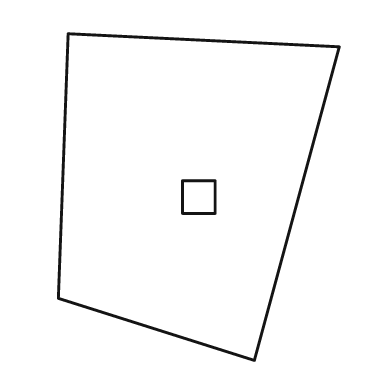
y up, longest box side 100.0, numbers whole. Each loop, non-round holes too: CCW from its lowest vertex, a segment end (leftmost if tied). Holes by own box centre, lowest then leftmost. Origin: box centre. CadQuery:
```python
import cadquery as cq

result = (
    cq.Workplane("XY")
    .moveTo(17.0, -50.0)
    .lineTo(43.0, 46.0)
    .lineTo(-40.0, 50.0)
    .lineTo(-43.0, -31.0)
    .close()
    .moveTo(-5.0, -5.0)
    .lineTo(5.0, -5.0)
    .lineTo(5.0, 5.0)
    .lineTo(-5.0, 5.0)
    .close()
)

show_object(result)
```